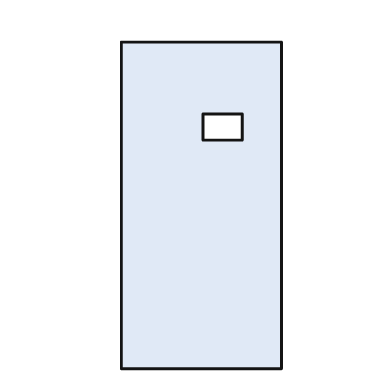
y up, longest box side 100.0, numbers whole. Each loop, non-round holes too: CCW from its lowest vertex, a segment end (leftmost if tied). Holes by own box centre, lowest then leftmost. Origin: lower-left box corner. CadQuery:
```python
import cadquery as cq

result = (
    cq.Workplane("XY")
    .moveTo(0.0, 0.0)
    .lineTo(49.0, 0.0)
    .lineTo(49.0, 100.0)
    .lineTo(0.0, 100.0)
    .close()
    .moveTo(25.0, 70.0)
    .lineTo(37.0, 70.0)
    .lineTo(37.0, 78.0)
    .lineTo(25.0, 78.0)
    .close()
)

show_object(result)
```